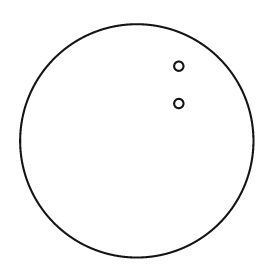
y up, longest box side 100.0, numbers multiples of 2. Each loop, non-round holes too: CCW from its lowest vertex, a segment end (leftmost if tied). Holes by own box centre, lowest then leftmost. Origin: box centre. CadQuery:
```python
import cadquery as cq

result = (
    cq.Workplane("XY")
    .moveTo(0.0, 0.0)
    .circle(50.0)
    .moveTo(18.0, 16.0)
    .circle(2.0)
    .moveTo(18.0, 32.0)
    .circle(2.0)
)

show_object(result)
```